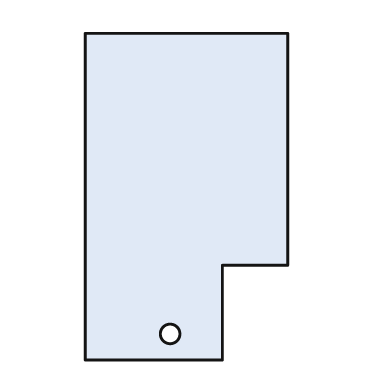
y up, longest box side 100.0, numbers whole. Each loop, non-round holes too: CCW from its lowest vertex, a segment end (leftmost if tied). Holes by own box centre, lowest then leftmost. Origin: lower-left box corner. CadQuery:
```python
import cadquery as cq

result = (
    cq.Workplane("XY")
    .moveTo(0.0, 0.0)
    .lineTo(42.0, 0.0)
    .lineTo(42.0, 29.0)
    .lineTo(62.0, 29.0)
    .lineTo(62.0, 100.0)
    .lineTo(0.0, 100.0)
    .close()
    .moveTo(26.0, 8.0)
    .circle(3.0)
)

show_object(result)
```